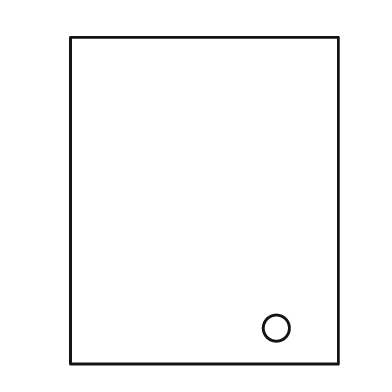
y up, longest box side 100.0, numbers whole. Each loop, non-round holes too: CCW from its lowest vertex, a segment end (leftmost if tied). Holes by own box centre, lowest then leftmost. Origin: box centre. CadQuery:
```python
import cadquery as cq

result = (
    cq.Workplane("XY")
    .moveTo(-41.0, -50.0)
    .lineTo(41.0, -50.0)
    .lineTo(41.0, 50.0)
    .lineTo(-41.0, 50.0)
    .close()
    .moveTo(22.0, -39.0)
    .circle(4.0)
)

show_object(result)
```